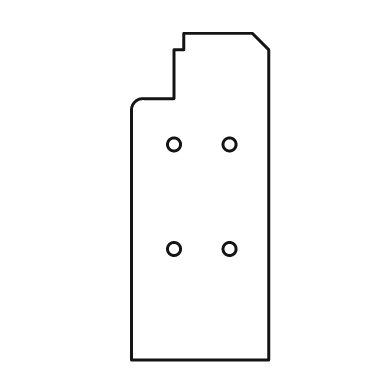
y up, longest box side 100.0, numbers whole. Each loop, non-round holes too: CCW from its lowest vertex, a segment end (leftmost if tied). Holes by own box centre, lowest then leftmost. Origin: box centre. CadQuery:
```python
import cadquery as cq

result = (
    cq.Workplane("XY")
    .moveTo(-21.0, -50.0)
    .lineTo(21.0, -50.0)
    .lineTo(21.0, 45.0)
    .lineTo(16.0, 50.0)
    .lineTo(-5.0, 50.0)
    .lineTo(-5.0, 45.0)
    .lineTo(-8.0, 45.0)
    .lineTo(-8.0, 30.0)
    .lineTo(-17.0, 30.0)
    .threePointArc((-20.0, 29.0), (-21.0, 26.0))
    .close()
    .moveTo(-8.0, -16.0)
    .circle(2.0)
    .moveTo(9.0, -16.0)
    .circle(2.0)
    .moveTo(-8.0, 16.0)
    .circle(2.0)
    .moveTo(9.0, 16.0)
    .circle(2.0)
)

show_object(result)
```